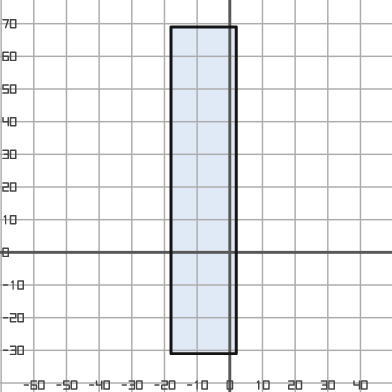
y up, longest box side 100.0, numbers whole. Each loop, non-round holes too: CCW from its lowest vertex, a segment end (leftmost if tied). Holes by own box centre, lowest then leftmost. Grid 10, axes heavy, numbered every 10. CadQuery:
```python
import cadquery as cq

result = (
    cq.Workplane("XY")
    .moveTo(-18.0, -31.0)
    .lineTo(2.0, -31.0)
    .lineTo(2.0, 69.0)
    .lineTo(-18.0, 69.0)
    .close()
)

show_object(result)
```